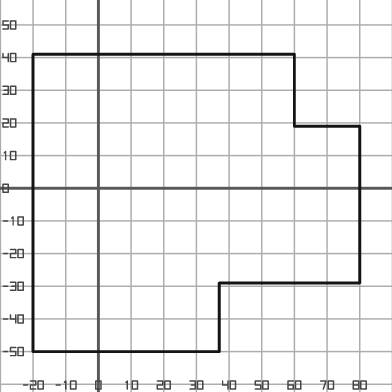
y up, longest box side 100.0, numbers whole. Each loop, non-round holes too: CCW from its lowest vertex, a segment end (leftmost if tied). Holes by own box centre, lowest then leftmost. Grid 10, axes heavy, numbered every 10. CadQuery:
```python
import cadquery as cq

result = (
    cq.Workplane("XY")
    .moveTo(-20.0, -50.0)
    .lineTo(37.0, -50.0)
    .lineTo(37.0, -29.0)
    .lineTo(80.0, -29.0)
    .lineTo(80.0, 19.0)
    .lineTo(60.0, 19.0)
    .lineTo(60.0, 41.0)
    .lineTo(-20.0, 41.0)
    .close()
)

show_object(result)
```